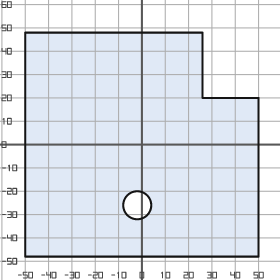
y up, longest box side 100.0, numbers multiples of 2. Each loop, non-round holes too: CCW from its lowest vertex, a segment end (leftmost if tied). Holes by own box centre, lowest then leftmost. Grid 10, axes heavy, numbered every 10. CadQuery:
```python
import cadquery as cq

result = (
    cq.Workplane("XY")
    .moveTo(-50.0, -48.0)
    .lineTo(50.0, -48.0)
    .lineTo(50.0, 20.0)
    .lineTo(26.0, 20.0)
    .lineTo(26.0, 48.0)
    .lineTo(-50.0, 48.0)
    .close()
    .moveTo(-2.0, -26.0)
    .circle(6.0)
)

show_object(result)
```